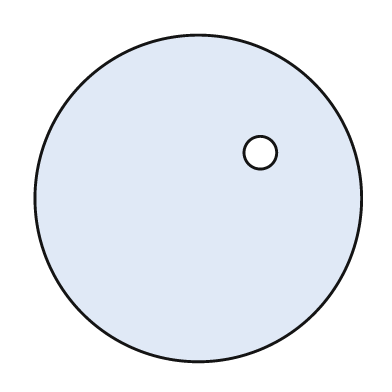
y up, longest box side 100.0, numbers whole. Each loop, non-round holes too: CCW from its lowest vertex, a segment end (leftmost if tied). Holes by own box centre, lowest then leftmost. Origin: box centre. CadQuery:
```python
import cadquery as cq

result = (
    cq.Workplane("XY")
    .moveTo(0.0, 0.0)
    .circle(50.0)
    .moveTo(19.0, 14.0)
    .circle(5.0)
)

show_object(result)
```